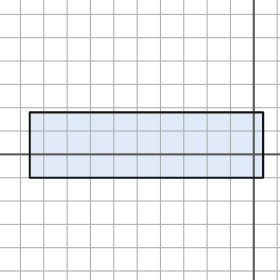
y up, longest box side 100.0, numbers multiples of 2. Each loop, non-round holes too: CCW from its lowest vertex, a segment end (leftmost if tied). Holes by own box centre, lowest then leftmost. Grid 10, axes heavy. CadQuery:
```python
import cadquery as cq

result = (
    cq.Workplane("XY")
    .moveTo(-96.0, -10.0)
    .lineTo(4.0, -10.0)
    .lineTo(4.0, 18.0)
    .lineTo(-96.0, 18.0)
    .close()
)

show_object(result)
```